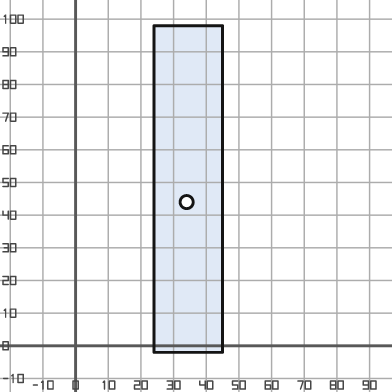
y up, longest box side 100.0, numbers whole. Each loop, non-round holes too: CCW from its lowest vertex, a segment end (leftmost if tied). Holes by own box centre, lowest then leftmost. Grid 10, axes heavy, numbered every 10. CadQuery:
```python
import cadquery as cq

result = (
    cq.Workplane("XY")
    .moveTo(24.0, -2.0)
    .lineTo(45.0, -2.0)
    .lineTo(45.0, 98.0)
    .lineTo(24.0, 98.0)
    .close()
    .moveTo(34.0, 44.0)
    .circle(2.0)
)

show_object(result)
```